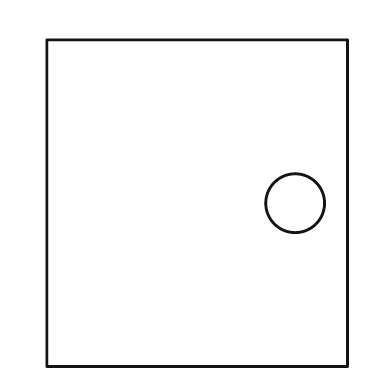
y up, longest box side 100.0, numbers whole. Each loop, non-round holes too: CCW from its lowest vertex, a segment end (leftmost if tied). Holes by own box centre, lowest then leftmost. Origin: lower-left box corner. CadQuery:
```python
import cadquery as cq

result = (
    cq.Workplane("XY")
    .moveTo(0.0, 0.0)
    .lineTo(92.0, 0.0)
    .lineTo(92.0, 100.0)
    .lineTo(0.0, 100.0)
    .close()
    .moveTo(76.0, 50.0)
    .circle(9.0)
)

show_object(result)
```